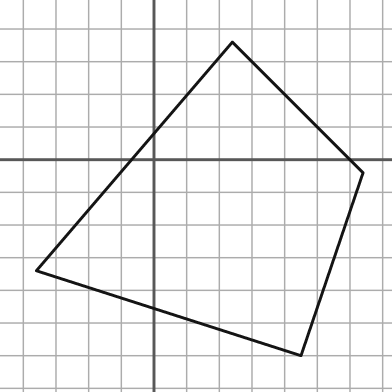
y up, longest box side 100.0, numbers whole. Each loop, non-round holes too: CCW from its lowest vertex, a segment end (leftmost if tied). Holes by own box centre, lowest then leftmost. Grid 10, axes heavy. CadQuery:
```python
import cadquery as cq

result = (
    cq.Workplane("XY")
    .moveTo(45.0, -60.0)
    .lineTo(64.0, -4.0)
    .lineTo(24.0, 36.0)
    .lineTo(-36.0, -34.0)
    .close()
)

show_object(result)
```